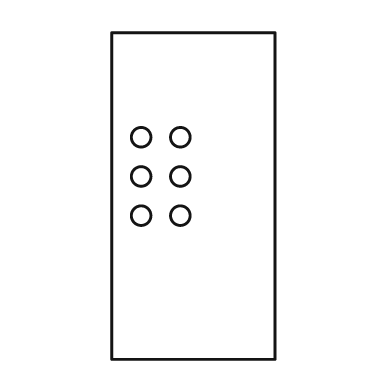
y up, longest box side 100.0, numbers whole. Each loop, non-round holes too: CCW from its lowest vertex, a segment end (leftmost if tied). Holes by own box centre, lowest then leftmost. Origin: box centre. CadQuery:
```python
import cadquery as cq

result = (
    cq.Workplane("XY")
    .moveTo(-25.0, -50.0)
    .lineTo(25.0, -50.0)
    .lineTo(25.0, 50.0)
    .lineTo(-25.0, 50.0)
    .close()
    .moveTo(-16.0, -6.0)
    .circle(3.0)
    .moveTo(-4.0, -6.0)
    .circle(3.0)
    .moveTo(-16.0, 6.0)
    .circle(3.0)
    .moveTo(-4.0, 6.0)
    .circle(3.0)
    .moveTo(-16.0, 18.0)
    .circle(3.0)
    .moveTo(-4.0, 18.0)
    .circle(3.0)
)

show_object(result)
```